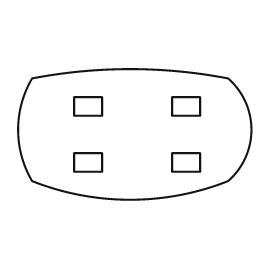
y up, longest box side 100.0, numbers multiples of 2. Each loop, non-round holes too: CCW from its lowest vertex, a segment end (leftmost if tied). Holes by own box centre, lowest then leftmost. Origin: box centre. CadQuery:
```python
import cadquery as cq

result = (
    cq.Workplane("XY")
    .moveTo(-44.0, -20.0)
    .threePointArc((-2.0, -28.0), (40.0, -20.0))
    .threePointArc((50.0, 2.0), (40.0, 24.0))
    .threePointArc((-2.0, 28.0), (-44.0, 24.0))
    .threePointArc((-50.0, 2.0), (-44.0, -20.0))
    .close()
    .moveTo(-26.0, -16.0)
    .lineTo(-14.0, -16.0)
    .lineTo(-14.0, -8.0)
    .lineTo(-26.0, -8.0)
    .close()
    .moveTo(16.0, -16.0)
    .lineTo(28.0, -16.0)
    .lineTo(28.0, -8.0)
    .lineTo(16.0, -8.0)
    .close()
    .moveTo(-26.0, 8.0)
    .lineTo(-14.0, 8.0)
    .lineTo(-14.0, 16.0)
    .lineTo(-26.0, 16.0)
    .close()
    .moveTo(16.0, 8.0)
    .lineTo(28.0, 8.0)
    .lineTo(28.0, 16.0)
    .lineTo(16.0, 16.0)
    .close()
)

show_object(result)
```